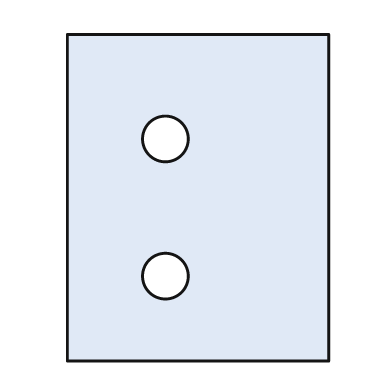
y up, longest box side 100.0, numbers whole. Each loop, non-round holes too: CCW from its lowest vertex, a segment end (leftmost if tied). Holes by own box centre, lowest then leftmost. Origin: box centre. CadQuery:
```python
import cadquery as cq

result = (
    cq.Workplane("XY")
    .moveTo(-40.0, -50.0)
    .lineTo(40.0, -50.0)
    .lineTo(40.0, 50.0)
    .lineTo(-40.0, 50.0)
    .close()
    .moveTo(-10.0, -24.0)
    .circle(7.0)
    .moveTo(-10.0, 18.0)
    .circle(7.0)
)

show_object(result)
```